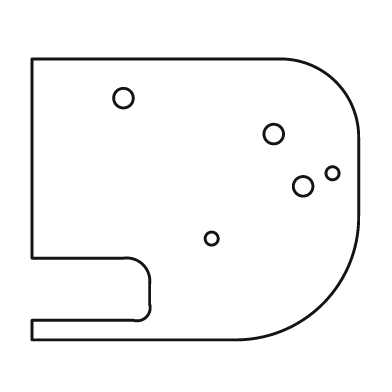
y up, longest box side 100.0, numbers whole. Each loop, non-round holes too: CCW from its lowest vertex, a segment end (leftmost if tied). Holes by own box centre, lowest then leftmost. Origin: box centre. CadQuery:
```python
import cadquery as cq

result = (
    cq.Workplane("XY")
    .moveTo(-50.0, -43.0)
    .lineTo(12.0, -43.0)
    .threePointArc((39.0, -32.0), (50.0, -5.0))
    .lineTo(50.0, 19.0)
    .threePointArc((43.0, 36.0), (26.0, 43.0))
    .lineTo(-50.0, 43.0)
    .lineTo(-50.0, -18.0)
    .lineTo(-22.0, -18.0)
    .threePointArc((-16.0, -20.0), (-14.0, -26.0))
    .lineTo(-14.0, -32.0)
    .threePointArc((-15.0, -36.0), (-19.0, -37.0))
    .lineTo(-50.0, -37.0)
    .close()
    .moveTo(5.0, -12.0)
    .circle(2.0)
    .moveTo(33.0, 4.0)
    .circle(3.0)
    .moveTo(42.0, 8.0)
    .circle(2.0)
    .moveTo(24.0, 20.0)
    .circle(3.0)
    .moveTo(-22.0, 31.0)
    .circle(3.0)
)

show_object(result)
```